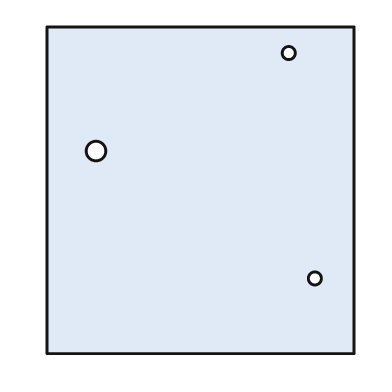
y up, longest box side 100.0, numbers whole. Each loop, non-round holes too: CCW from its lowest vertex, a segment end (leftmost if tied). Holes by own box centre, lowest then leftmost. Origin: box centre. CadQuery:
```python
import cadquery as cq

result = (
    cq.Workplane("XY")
    .moveTo(-47.0, -50.0)
    .lineTo(47.0, -50.0)
    .lineTo(47.0, 50.0)
    .lineTo(-47.0, 50.0)
    .close()
    .moveTo(35.0, -27.0)
    .circle(2.0)
    .moveTo(-32.0, 12.0)
    .circle(3.0)
    .moveTo(27.0, 42.0)
    .circle(2.0)
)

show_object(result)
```